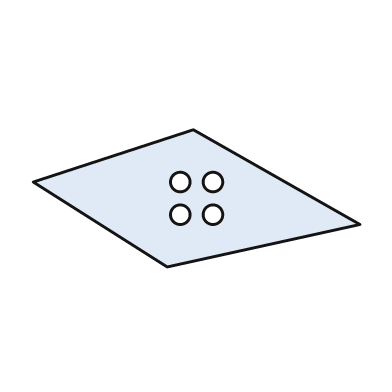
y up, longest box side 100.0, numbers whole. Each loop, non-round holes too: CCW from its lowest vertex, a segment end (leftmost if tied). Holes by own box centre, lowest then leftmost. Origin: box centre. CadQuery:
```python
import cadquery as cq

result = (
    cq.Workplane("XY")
    .moveTo(-9.0, -21.0)
    .lineTo(50.0, -8.0)
    .lineTo(-1.0, 21.0)
    .lineTo(-50.0, 5.0)
    .close()
    .moveTo(-5.0, -5.0)
    .circle(3.0)
    .moveTo(5.0, -5.0)
    .circle(3.0)
    .moveTo(-5.0, 5.0)
    .circle(3.0)
    .moveTo(5.0, 5.0)
    .circle(3.0)
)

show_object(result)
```